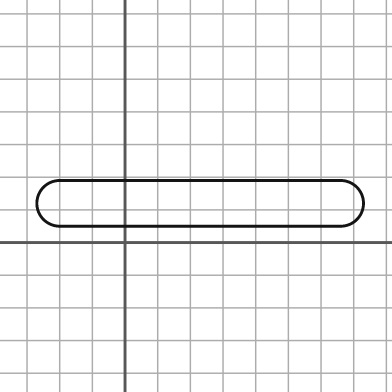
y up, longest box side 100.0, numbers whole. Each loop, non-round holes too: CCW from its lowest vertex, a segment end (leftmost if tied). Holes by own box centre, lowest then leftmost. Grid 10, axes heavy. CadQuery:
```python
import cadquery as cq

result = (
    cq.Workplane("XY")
    .moveTo(-20.0, 5.0)
    .lineTo(66.0, 5.0)
    .threePointArc((73.0, 12.0), (66.0, 19.0))
    .lineTo(-20.0, 19.0)
    .threePointArc((-27.0, 12.0), (-20.0, 5.0))
    .close()
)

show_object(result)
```